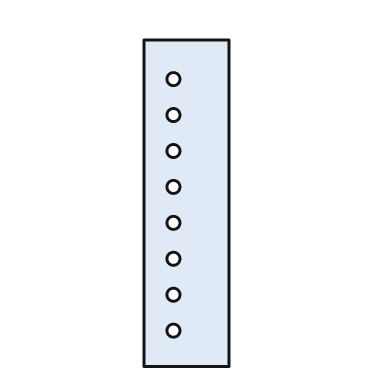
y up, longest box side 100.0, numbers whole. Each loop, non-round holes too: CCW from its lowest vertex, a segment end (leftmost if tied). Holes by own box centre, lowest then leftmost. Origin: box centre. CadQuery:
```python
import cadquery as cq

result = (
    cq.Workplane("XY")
    .moveTo(-13.0, -50.0)
    .lineTo(13.0, -50.0)
    .lineTo(13.0, 50.0)
    .lineTo(-13.0, 50.0)
    .close()
    .moveTo(-4.0, -39.0)
    .circle(2.0)
    .moveTo(-4.0, -28.0)
    .circle(2.0)
    .moveTo(-4.0, -17.0)
    .circle(2.0)
    .moveTo(-4.0, -6.0)
    .circle(2.0)
    .moveTo(-4.0, 5.0)
    .circle(2.0)
    .moveTo(-4.0, 16.0)
    .circle(2.0)
    .moveTo(-4.0, 27.0)
    .circle(2.0)
    .moveTo(-4.0, 38.0)
    .circle(2.0)
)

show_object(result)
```